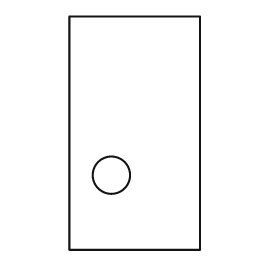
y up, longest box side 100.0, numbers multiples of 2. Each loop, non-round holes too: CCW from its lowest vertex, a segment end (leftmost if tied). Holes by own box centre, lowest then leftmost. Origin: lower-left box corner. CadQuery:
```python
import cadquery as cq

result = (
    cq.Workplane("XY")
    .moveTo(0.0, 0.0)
    .lineTo(56.0, 0.0)
    .lineTo(56.0, 100.0)
    .lineTo(0.0, 100.0)
    .close()
    .moveTo(18.0, 32.0)
    .circle(8.0)
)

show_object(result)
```